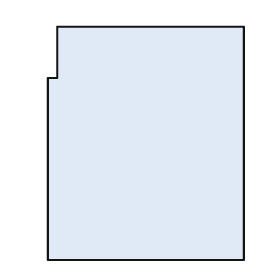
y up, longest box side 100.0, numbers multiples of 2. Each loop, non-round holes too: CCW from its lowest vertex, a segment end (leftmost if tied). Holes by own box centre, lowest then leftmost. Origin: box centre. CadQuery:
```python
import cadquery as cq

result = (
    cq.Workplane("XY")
    .moveTo(-42.0, -50.0)
    .lineTo(42.0, -50.0)
    .lineTo(42.0, 50.0)
    .lineTo(-38.0, 50.0)
    .lineTo(-38.0, 28.0)
    .lineTo(-42.0, 28.0)
    .close()
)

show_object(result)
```